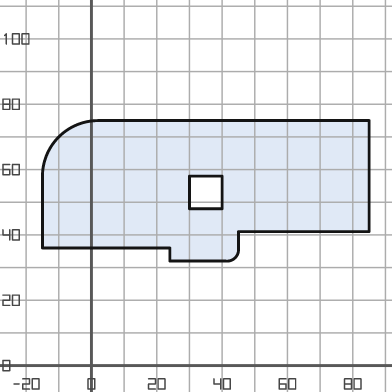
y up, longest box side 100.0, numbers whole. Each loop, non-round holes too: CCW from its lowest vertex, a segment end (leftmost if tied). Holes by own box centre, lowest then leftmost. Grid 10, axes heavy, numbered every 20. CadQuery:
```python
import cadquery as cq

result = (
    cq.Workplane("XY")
    .moveTo(24.0, 32.0)
    .lineTo(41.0, 32.0)
    .threePointArc((44.0, 33.0), (45.0, 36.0))
    .lineTo(45.0, 41.0)
    .lineTo(85.0, 41.0)
    .lineTo(85.0, 75.0)
    .lineTo(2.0, 75.0)
    .threePointArc((-10.0, 70.0), (-15.0, 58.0))
    .lineTo(-15.0, 36.0)
    .lineTo(24.0, 36.0)
    .close()
    .moveTo(30.0, 48.0)
    .lineTo(40.0, 48.0)
    .lineTo(40.0, 58.0)
    .lineTo(30.0, 58.0)
    .close()
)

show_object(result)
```